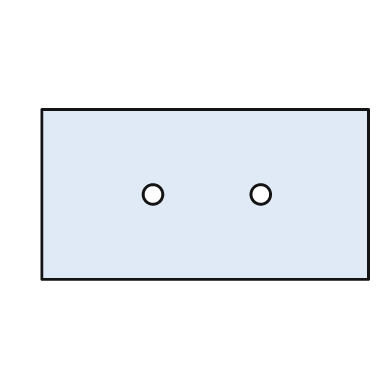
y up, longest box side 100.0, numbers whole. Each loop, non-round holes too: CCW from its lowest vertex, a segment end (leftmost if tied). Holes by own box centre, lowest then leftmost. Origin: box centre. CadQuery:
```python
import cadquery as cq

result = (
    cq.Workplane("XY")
    .moveTo(-50.0, -26.0)
    .lineTo(50.0, -26.0)
    .lineTo(50.0, 26.0)
    .lineTo(-50.0, 26.0)
    .close()
    .moveTo(-16.0, 0.0)
    .circle(3.0)
    .moveTo(17.0, 0.0)
    .circle(3.0)
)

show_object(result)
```